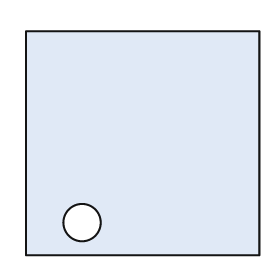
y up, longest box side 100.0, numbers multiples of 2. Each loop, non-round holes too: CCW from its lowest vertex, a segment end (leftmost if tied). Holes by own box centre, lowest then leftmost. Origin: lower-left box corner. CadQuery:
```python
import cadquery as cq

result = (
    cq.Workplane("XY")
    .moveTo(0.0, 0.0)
    .lineTo(100.0, 0.0)
    .lineTo(100.0, 96.0)
    .lineTo(0.0, 96.0)
    .close()
    .moveTo(24.0, 14.0)
    .circle(8.0)
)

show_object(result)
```